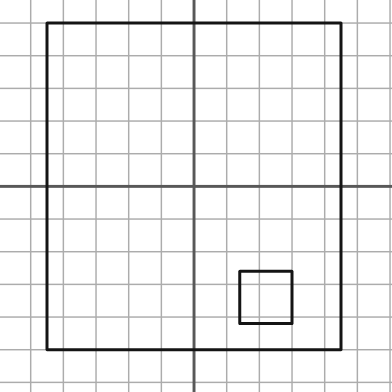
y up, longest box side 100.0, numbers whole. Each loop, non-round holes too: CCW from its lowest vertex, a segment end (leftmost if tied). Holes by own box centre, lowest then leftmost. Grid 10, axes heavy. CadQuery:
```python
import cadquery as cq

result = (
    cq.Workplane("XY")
    .moveTo(-45.0, -50.0)
    .lineTo(45.0, -50.0)
    .lineTo(45.0, 50.0)
    .lineTo(-45.0, 50.0)
    .close()
    .moveTo(14.0, -42.0)
    .lineTo(30.0, -42.0)
    .lineTo(30.0, -26.0)
    .lineTo(14.0, -26.0)
    .close()
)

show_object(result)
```